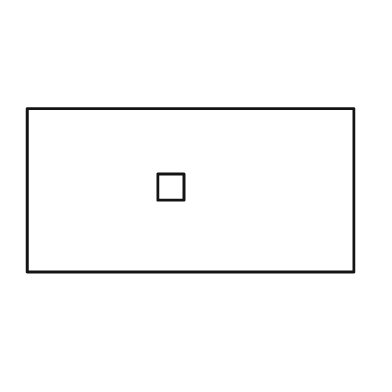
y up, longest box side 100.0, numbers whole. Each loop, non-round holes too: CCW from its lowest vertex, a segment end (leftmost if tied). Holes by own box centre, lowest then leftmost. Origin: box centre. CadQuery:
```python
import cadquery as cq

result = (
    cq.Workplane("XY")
    .moveTo(-50.0, -25.0)
    .lineTo(50.0, -25.0)
    .lineTo(50.0, 25.0)
    .lineTo(-50.0, 25.0)
    .close()
    .moveTo(-10.0, -3.0)
    .lineTo(-2.0, -3.0)
    .lineTo(-2.0, 5.0)
    .lineTo(-10.0, 5.0)
    .close()
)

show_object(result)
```